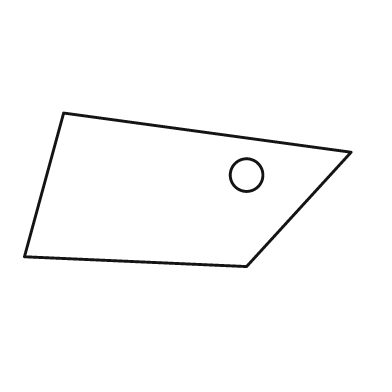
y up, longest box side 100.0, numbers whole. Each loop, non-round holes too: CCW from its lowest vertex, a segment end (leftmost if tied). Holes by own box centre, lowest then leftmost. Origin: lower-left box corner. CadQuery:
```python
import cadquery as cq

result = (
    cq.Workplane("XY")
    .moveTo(68.0, 0.0)
    .lineTo(100.0, 35.0)
    .lineTo(12.0, 47.0)
    .lineTo(0.0, 3.0)
    .close()
    .moveTo(68.0, 28.0)
    .circle(5.0)
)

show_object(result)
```